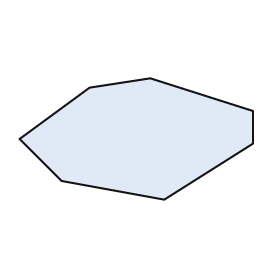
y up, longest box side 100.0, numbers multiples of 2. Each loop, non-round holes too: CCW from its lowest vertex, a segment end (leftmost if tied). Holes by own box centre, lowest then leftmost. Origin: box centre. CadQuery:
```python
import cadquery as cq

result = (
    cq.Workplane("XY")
    .moveTo(12.0, -26.0)
    .lineTo(50.0, -2.0)
    .lineTo(50.0, 12.0)
    .lineTo(6.0, 26.0)
    .lineTo(-20.0, 22.0)
    .lineTo(-50.0, 0.0)
    .lineTo(-32.0, -18.0)
    .close()
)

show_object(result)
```